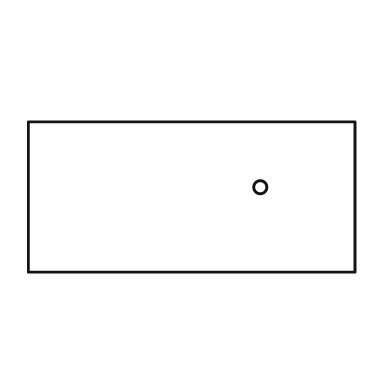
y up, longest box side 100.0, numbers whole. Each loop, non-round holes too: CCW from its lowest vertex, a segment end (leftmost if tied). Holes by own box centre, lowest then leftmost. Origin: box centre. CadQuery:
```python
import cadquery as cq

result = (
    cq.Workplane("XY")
    .moveTo(-50.0, -23.0)
    .lineTo(50.0, -23.0)
    .lineTo(50.0, 23.0)
    .lineTo(-50.0, 23.0)
    .close()
    .moveTo(21.0, 3.0)
    .circle(2.0)
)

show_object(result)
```